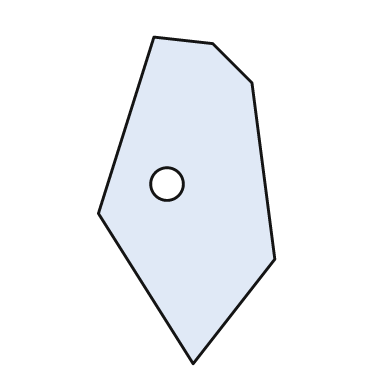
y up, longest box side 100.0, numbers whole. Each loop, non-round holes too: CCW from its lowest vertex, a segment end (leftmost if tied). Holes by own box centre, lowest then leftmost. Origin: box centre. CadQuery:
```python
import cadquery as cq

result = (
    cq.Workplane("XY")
    .moveTo(2.0, -50.0)
    .lineTo(27.0, -18.0)
    .lineTo(20.0, 36.0)
    .lineTo(8.0, 48.0)
    .lineTo(-10.0, 50.0)
    .lineTo(-27.0, -4.0)
    .close()
    .moveTo(-6.0, 5.0)
    .circle(5.0)
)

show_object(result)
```